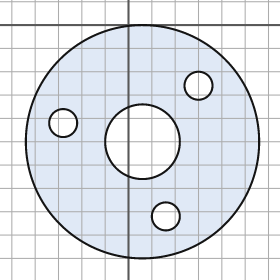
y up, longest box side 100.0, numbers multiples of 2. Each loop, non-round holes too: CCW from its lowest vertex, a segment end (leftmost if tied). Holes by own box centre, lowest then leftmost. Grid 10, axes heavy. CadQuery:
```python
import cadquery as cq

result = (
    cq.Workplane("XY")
    .moveTo(6.0, -50.0)
    .circle(50.0)
    .moveTo(16.0, -82.0)
    .circle(6.0)
    .moveTo(6.0, -50.0)
    .circle(16.0)
    .moveTo(-28.0, -42.0)
    .circle(6.0)
    .moveTo(30.0, -26.0)
    .circle(6.0)
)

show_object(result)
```